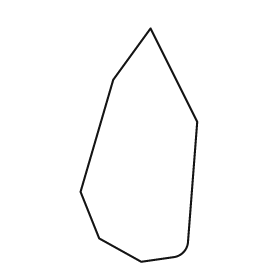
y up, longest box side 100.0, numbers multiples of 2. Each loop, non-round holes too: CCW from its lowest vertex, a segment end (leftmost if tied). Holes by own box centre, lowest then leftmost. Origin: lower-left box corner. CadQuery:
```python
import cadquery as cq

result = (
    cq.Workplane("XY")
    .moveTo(26.0, 0.0)
    .lineTo(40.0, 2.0)
    .threePointArc((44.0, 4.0), (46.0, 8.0))
    .lineTo(50.0, 60.0)
    .lineTo(30.0, 100.0)
    .lineTo(14.0, 78.0)
    .lineTo(0.0, 30.0)
    .lineTo(8.0, 10.0)
    .close()
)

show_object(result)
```